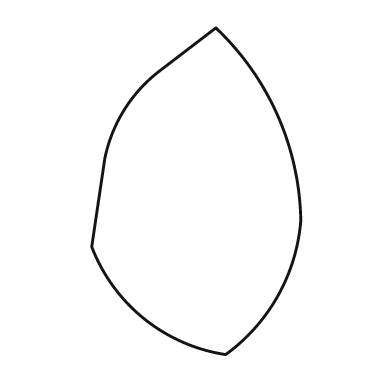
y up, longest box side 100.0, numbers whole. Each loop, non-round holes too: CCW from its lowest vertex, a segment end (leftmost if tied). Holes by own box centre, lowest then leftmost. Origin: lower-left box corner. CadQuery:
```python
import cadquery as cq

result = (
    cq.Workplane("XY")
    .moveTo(41.0, 0.0)
    .threePointArc((57.0, 18.0), (64.0, 41.0))
    .threePointArc((57.0, 73.0), (38.0, 100.0))
    .lineTo(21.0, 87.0)
    .threePointArc((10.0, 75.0), (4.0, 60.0))
    .lineTo(0.0, 33.0)
    .threePointArc((16.0, 11.0), (41.0, 0.0))
    .close()
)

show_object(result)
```